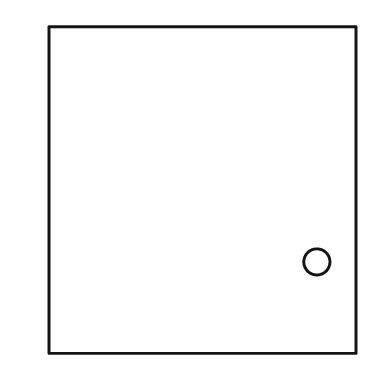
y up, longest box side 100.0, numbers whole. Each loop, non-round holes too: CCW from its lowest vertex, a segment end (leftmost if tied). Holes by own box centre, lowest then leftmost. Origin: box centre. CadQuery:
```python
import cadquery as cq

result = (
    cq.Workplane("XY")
    .moveTo(-47.0, -50.0)
    .lineTo(47.0, -50.0)
    .lineTo(47.0, 50.0)
    .lineTo(-47.0, 50.0)
    .close()
    .moveTo(35.0, -22.0)
    .circle(4.0)
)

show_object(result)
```